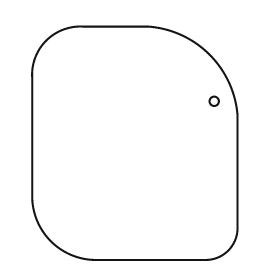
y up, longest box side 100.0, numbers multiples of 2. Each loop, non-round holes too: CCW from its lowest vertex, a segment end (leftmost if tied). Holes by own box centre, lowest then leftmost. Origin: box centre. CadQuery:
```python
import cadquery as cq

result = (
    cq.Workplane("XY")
    .moveTo(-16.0, -50.0)
    .lineTo(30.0, -50.0)
    .threePointArc((40.0, -46.0), (44.0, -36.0))
    .lineTo(44.0, 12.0)
    .threePointArc((32.0, 38.0), (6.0, 50.0))
    .lineTo(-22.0, 50.0)
    .threePointArc((-38.0, 44.0), (-44.0, 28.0))
    .lineTo(-44.0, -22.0)
    .threePointArc((-36.0, -42.0), (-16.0, -50.0))
    .close()
    .moveTo(34.0, 18.0)
    .circle(2.0)
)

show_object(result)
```